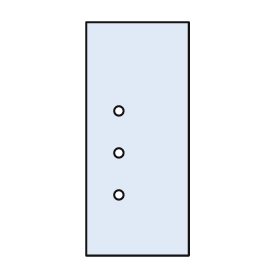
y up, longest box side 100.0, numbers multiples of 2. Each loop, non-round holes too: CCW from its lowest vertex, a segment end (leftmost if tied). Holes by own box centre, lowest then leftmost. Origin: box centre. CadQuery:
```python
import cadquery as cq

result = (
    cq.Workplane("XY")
    .moveTo(-22.0, -50.0)
    .lineTo(22.0, -50.0)
    .lineTo(22.0, 50.0)
    .lineTo(-22.0, 50.0)
    .close()
    .moveTo(-8.0, -24.0)
    .circle(2.0)
    .moveTo(-8.0, -6.0)
    .circle(2.0)
    .moveTo(-8.0, 12.0)
    .circle(2.0)
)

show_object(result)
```